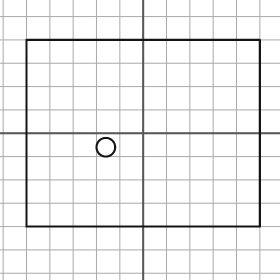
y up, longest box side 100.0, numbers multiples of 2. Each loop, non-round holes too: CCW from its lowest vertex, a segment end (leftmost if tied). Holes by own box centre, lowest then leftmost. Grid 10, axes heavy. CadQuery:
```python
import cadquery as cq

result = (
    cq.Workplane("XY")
    .moveTo(-50.0, -40.0)
    .lineTo(50.0, -40.0)
    .lineTo(50.0, 40.0)
    .lineTo(-50.0, 40.0)
    .close()
    .moveTo(-16.0, -6.0)
    .circle(4.0)
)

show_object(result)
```